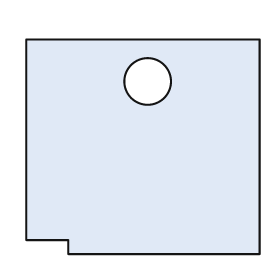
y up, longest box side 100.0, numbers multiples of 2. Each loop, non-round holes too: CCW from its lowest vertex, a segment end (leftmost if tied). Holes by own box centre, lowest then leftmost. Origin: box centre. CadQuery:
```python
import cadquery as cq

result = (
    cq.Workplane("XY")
    .moveTo(-32.0, -46.0)
    .lineTo(50.0, -46.0)
    .lineTo(50.0, 46.0)
    .lineTo(-50.0, 46.0)
    .lineTo(-50.0, -40.0)
    .lineTo(-32.0, -40.0)
    .close()
    .moveTo(2.0, 28.0)
    .circle(10.0)
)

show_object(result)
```